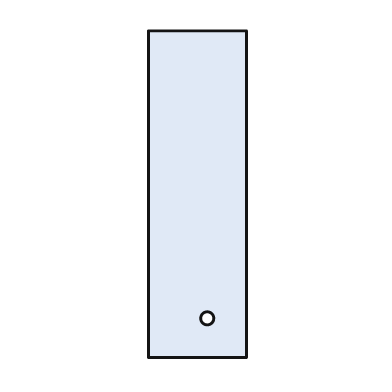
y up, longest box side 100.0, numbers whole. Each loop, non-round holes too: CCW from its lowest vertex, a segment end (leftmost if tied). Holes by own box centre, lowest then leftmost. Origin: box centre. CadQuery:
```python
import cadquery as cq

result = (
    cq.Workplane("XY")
    .moveTo(-15.0, -50.0)
    .lineTo(15.0, -50.0)
    .lineTo(15.0, 50.0)
    .lineTo(-15.0, 50.0)
    .close()
    .moveTo(3.0, -38.0)
    .circle(2.0)
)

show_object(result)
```